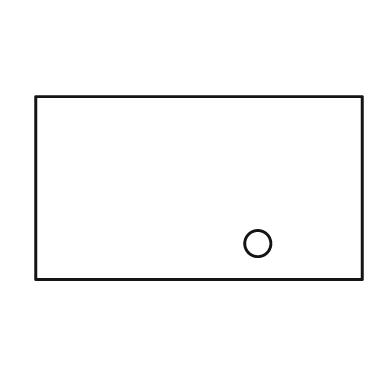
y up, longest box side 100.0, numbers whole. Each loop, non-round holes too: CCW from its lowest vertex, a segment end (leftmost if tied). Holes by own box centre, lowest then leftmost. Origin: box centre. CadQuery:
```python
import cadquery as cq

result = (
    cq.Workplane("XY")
    .moveTo(-50.0, -28.0)
    .lineTo(50.0, -28.0)
    .lineTo(50.0, 28.0)
    .lineTo(-50.0, 28.0)
    .close()
    .moveTo(18.0, -17.0)
    .circle(4.0)
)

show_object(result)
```